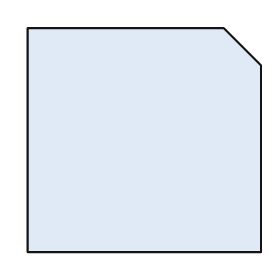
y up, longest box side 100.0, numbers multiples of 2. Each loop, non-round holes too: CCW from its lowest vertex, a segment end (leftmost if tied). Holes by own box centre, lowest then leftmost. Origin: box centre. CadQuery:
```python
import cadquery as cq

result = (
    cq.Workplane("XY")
    .moveTo(-50.0, -48.0)
    .lineTo(50.0, -48.0)
    .lineTo(50.0, 32.0)
    .lineTo(34.0, 48.0)
    .lineTo(-50.0, 48.0)
    .close()
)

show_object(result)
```